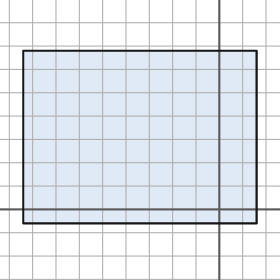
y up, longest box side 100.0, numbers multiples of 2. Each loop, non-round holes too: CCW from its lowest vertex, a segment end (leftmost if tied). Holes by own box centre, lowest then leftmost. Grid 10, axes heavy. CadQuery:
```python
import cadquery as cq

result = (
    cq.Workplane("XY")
    .moveTo(-84.0, -6.0)
    .lineTo(16.0, -6.0)
    .lineTo(16.0, 68.0)
    .lineTo(-84.0, 68.0)
    .close()
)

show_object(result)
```